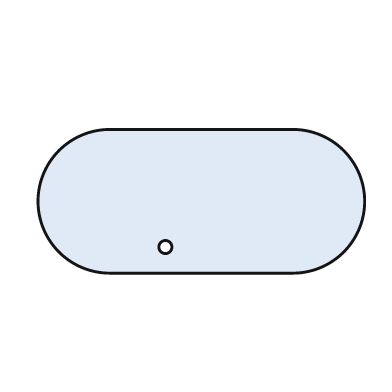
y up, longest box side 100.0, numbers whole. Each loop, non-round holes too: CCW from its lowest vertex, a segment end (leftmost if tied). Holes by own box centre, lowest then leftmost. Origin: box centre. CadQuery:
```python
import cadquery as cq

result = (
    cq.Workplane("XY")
    .moveTo(-28.0, -22.0)
    .lineTo(28.0, -22.0)
    .threePointArc((50.0, 0.0), (28.0, 22.0))
    .lineTo(-28.0, 22.0)
    .threePointArc((-50.0, 0.0), (-28.0, -22.0))
    .close()
    .moveTo(-11.0, -14.0)
    .circle(2.0)
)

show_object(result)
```